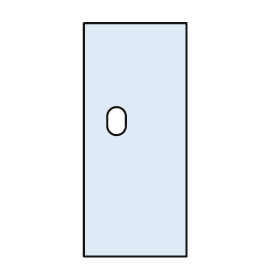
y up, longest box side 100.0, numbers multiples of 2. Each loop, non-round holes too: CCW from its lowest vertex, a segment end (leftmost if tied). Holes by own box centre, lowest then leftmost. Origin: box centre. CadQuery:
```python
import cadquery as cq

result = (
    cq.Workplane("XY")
    .moveTo(-22.0, -50.0)
    .lineTo(22.0, -50.0)
    .lineTo(22.0, 50.0)
    .lineTo(-22.0, 50.0)
    .close()
    .moveTo(-12.0, 6.0)
    .threePointArc((-8.0, 2.0), (-4.0, 6.0))
    .lineTo(-4.0, 10.0)
    .threePointArc((-8.0, 14.0), (-12.0, 10.0))
    .close()
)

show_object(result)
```